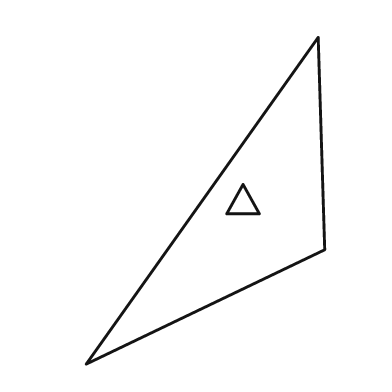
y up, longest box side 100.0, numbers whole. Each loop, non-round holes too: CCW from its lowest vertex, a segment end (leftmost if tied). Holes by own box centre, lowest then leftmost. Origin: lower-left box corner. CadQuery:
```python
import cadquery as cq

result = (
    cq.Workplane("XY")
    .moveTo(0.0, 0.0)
    .lineTo(73.0, 35.0)
    .lineTo(71.0, 100.0)
    .close()
    .moveTo(43.0, 46.0)
    .lineTo(53.0, 46.0)
    .lineTo(48.0, 55.0)
    .close()
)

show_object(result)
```